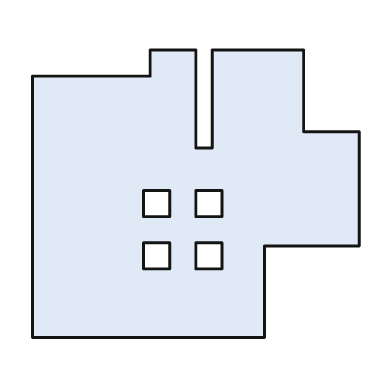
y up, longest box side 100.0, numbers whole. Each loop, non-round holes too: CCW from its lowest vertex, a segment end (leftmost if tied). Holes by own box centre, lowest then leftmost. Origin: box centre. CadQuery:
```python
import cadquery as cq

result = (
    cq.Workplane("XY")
    .moveTo(-50.0, -44.0)
    .lineTo(21.0, -44.0)
    .lineTo(21.0, -16.0)
    .lineTo(50.0, -16.0)
    .lineTo(50.0, 19.0)
    .lineTo(33.0, 19.0)
    .lineTo(33.0, 44.0)
    .lineTo(5.0, 44.0)
    .lineTo(5.0, 14.0)
    .lineTo(0.0, 14.0)
    .lineTo(0.0, 44.0)
    .lineTo(-14.0, 44.0)
    .lineTo(-14.0, 36.0)
    .lineTo(-50.0, 36.0)
    .close()
    .moveTo(-16.0, -23.0)
    .lineTo(-8.0, -23.0)
    .lineTo(-8.0, -15.0)
    .lineTo(-16.0, -15.0)
    .close()
    .moveTo(0.0, -23.0)
    .lineTo(8.0, -23.0)
    .lineTo(8.0, -15.0)
    .lineTo(0.0, -15.0)
    .close()
    .moveTo(-16.0, -7.0)
    .lineTo(-8.0, -7.0)
    .lineTo(-8.0, 1.0)
    .lineTo(-16.0, 1.0)
    .close()
    .moveTo(0.0, -7.0)
    .lineTo(8.0, -7.0)
    .lineTo(8.0, 1.0)
    .lineTo(0.0, 1.0)
    .close()
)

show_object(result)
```